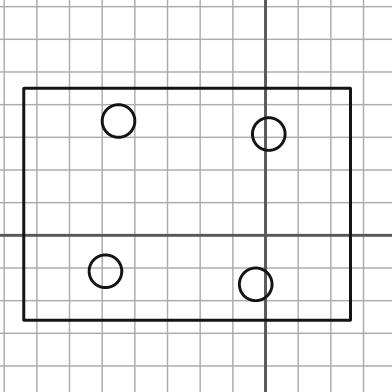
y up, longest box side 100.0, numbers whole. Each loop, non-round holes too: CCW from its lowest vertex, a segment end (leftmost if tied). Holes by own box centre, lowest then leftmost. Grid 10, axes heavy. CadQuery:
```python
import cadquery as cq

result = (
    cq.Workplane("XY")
    .moveTo(-74.0, -26.0)
    .lineTo(26.0, -26.0)
    .lineTo(26.0, 45.0)
    .lineTo(-74.0, 45.0)
    .close()
    .moveTo(-3.0, -15.0)
    .circle(5.0)
    .moveTo(-49.0, -11.0)
    .circle(5.0)
    .moveTo(1.0, 31.0)
    .circle(5.0)
    .moveTo(-45.0, 35.0)
    .circle(5.0)
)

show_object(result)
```